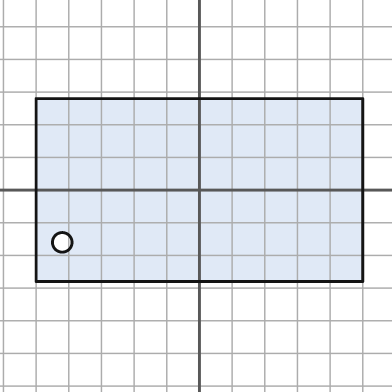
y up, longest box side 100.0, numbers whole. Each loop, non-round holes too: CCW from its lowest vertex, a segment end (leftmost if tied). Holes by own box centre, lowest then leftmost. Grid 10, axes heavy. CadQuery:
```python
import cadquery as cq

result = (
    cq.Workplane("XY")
    .moveTo(-50.0, -28.0)
    .lineTo(50.0, -28.0)
    .lineTo(50.0, 28.0)
    .lineTo(-50.0, 28.0)
    .close()
    .moveTo(-42.0, -16.0)
    .circle(3.0)
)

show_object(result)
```